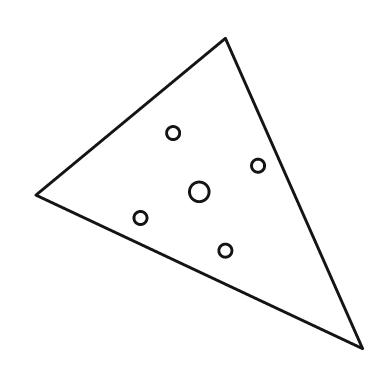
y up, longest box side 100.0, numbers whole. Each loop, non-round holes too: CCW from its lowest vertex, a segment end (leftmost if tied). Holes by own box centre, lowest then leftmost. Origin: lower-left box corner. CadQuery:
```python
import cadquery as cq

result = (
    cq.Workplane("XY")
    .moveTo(100.0, 0.0)
    .lineTo(58.0, 95.0)
    .lineTo(0.0, 47.0)
    .close()
    .moveTo(58.0, 30.0)
    .circle(2.0)
    .moveTo(32.0, 40.0)
    .circle(2.0)
    .moveTo(50.0, 48.0)
    .circle(3.0)
    .moveTo(68.0, 56.0)
    .circle(2.0)
    .moveTo(42.0, 66.0)
    .circle(2.0)
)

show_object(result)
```